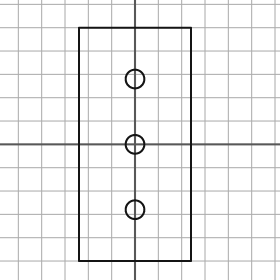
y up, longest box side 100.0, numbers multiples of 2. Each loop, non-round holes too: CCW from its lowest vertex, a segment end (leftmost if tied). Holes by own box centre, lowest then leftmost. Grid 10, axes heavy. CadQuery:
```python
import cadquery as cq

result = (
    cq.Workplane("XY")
    .moveTo(-24.0, -50.0)
    .lineTo(24.0, -50.0)
    .lineTo(24.0, 50.0)
    .lineTo(-24.0, 50.0)
    .close()
    .moveTo(0.0, -28.0)
    .circle(4.0)
    .moveTo(0.0, 0.0)
    .circle(4.0)
    .moveTo(0.0, 28.0)
    .circle(4.0)
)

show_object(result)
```